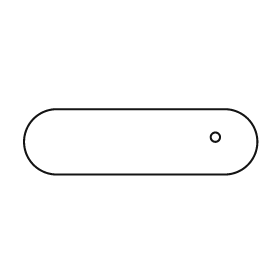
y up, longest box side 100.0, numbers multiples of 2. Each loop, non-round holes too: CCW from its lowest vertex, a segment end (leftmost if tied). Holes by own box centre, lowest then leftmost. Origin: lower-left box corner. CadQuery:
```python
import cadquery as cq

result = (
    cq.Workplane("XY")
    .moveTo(14.0, 0.0)
    .lineTo(86.0, 0.0)
    .threePointArc((100.0, 14.0), (86.0, 28.0))
    .lineTo(14.0, 28.0)
    .threePointArc((0.0, 14.0), (14.0, 0.0))
    .close()
    .moveTo(82.0, 16.0)
    .circle(2.0)
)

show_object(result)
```